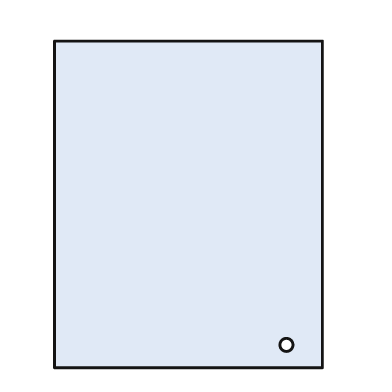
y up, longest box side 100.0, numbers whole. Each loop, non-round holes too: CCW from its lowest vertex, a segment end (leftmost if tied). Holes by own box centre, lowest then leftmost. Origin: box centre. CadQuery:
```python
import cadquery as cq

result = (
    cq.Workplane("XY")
    .moveTo(-41.0, -50.0)
    .lineTo(41.0, -50.0)
    .lineTo(41.0, 50.0)
    .lineTo(-41.0, 50.0)
    .close()
    .moveTo(30.0, -43.0)
    .circle(2.0)
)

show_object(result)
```